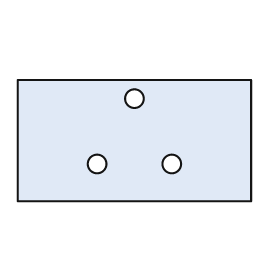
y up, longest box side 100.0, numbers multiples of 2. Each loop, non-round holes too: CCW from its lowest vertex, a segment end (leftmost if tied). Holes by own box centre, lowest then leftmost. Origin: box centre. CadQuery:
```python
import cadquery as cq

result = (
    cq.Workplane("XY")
    .moveTo(-50.0, -26.0)
    .lineTo(50.0, -26.0)
    .lineTo(50.0, 26.0)
    .lineTo(-50.0, 26.0)
    .close()
    .moveTo(-16.0, -10.0)
    .circle(4.0)
    .moveTo(16.0, -10.0)
    .circle(4.0)
    .moveTo(0.0, 18.0)
    .circle(4.0)
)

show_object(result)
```